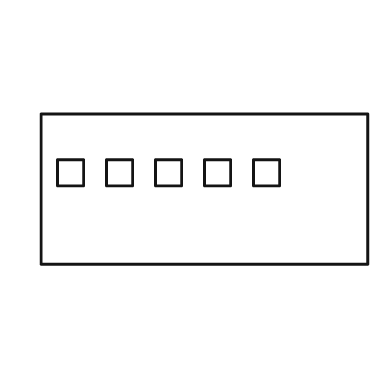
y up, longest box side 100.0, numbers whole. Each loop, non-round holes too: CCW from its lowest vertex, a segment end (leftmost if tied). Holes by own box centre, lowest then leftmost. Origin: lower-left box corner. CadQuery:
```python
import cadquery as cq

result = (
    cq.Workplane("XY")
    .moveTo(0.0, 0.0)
    .lineTo(100.0, 0.0)
    .lineTo(100.0, 46.0)
    .lineTo(0.0, 46.0)
    .close()
    .moveTo(5.0, 24.0)
    .lineTo(13.0, 24.0)
    .lineTo(13.0, 32.0)
    .lineTo(5.0, 32.0)
    .close()
    .moveTo(20.0, 24.0)
    .lineTo(28.0, 24.0)
    .lineTo(28.0, 32.0)
    .lineTo(20.0, 32.0)
    .close()
    .moveTo(35.0, 24.0)
    .lineTo(43.0, 24.0)
    .lineTo(43.0, 32.0)
    .lineTo(35.0, 32.0)
    .close()
    .moveTo(50.0, 24.0)
    .lineTo(58.0, 24.0)
    .lineTo(58.0, 32.0)
    .lineTo(50.0, 32.0)
    .close()
    .moveTo(65.0, 24.0)
    .lineTo(73.0, 24.0)
    .lineTo(73.0, 32.0)
    .lineTo(65.0, 32.0)
    .close()
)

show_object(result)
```